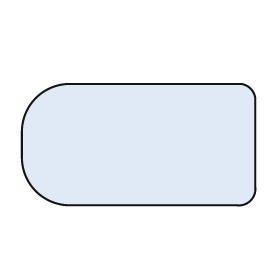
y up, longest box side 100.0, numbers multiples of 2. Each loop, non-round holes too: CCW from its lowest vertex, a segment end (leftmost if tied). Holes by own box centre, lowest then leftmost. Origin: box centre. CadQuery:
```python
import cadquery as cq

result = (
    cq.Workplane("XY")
    .moveTo(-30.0, -26.0)
    .lineTo(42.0, -26.0)
    .threePointArc((48.0, -24.0), (50.0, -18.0))
    .lineTo(50.0, 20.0)
    .threePointArc((48.0, 24.0), (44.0, 26.0))
    .lineTo(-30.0, 26.0)
    .threePointArc((-44.0, 20.0), (-50.0, 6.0))
    .lineTo(-50.0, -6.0)
    .threePointArc((-44.0, -20.0), (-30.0, -26.0))
    .close()
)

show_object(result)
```